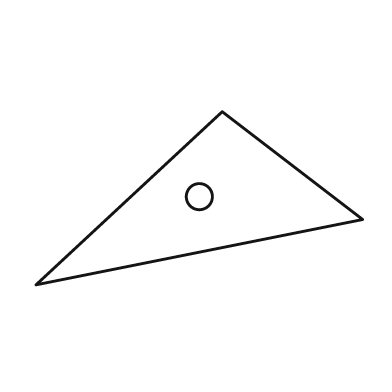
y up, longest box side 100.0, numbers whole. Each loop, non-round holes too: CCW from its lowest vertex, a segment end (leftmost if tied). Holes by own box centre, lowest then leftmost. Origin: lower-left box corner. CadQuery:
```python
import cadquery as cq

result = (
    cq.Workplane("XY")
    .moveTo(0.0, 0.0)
    .lineTo(100.0, 20.0)
    .lineTo(57.0, 53.0)
    .close()
    .moveTo(50.0, 27.0)
    .circle(4.0)
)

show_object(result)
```